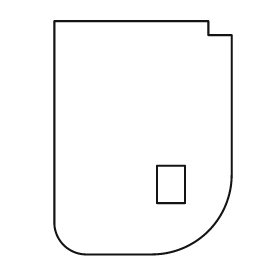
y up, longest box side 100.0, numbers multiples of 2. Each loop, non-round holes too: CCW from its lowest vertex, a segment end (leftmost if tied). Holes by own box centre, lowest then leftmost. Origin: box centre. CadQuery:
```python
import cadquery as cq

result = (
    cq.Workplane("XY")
    .moveTo(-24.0, -50.0)
    .lineTo(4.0, -50.0)
    .threePointArc((28.0, -40.0), (38.0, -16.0))
    .lineTo(38.0, 44.0)
    .lineTo(28.0, 44.0)
    .lineTo(28.0, 50.0)
    .lineTo(-38.0, 50.0)
    .lineTo(-38.0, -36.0)
    .threePointArc((-34.0, -46.0), (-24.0, -50.0))
    .close()
    .moveTo(6.0, -28.0)
    .lineTo(18.0, -28.0)
    .lineTo(18.0, -12.0)
    .lineTo(6.0, -12.0)
    .close()
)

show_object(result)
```